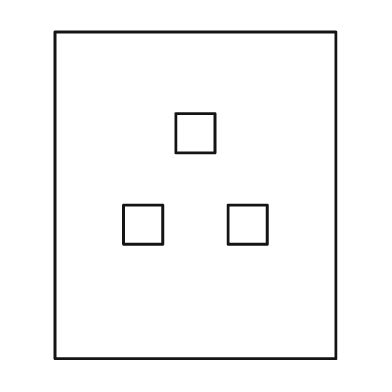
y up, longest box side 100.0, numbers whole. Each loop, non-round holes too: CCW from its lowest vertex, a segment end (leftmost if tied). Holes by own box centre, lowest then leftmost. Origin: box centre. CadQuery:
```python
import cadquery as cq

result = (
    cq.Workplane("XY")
    .moveTo(-43.0, -50.0)
    .lineTo(43.0, -50.0)
    .lineTo(43.0, 50.0)
    .lineTo(-43.0, 50.0)
    .close()
    .moveTo(-22.0, -15.0)
    .lineTo(-10.0, -15.0)
    .lineTo(-10.0, -3.0)
    .lineTo(-22.0, -3.0)
    .close()
    .moveTo(10.0, -15.0)
    .lineTo(22.0, -15.0)
    .lineTo(22.0, -3.0)
    .lineTo(10.0, -3.0)
    .close()
    .moveTo(-6.0, 13.0)
    .lineTo(6.0, 13.0)
    .lineTo(6.0, 25.0)
    .lineTo(-6.0, 25.0)
    .close()
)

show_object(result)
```